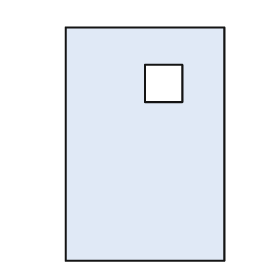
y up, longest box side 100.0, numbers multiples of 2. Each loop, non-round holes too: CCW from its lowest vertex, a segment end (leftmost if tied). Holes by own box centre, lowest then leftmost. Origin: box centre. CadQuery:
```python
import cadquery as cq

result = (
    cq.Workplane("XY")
    .moveTo(-34.0, -50.0)
    .lineTo(34.0, -50.0)
    .lineTo(34.0, 50.0)
    .lineTo(-34.0, 50.0)
    .close()
    .moveTo(0.0, 18.0)
    .lineTo(16.0, 18.0)
    .lineTo(16.0, 34.0)
    .lineTo(0.0, 34.0)
    .close()
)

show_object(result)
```